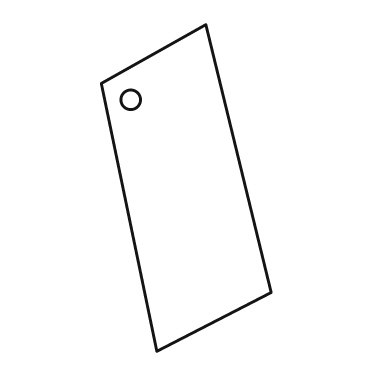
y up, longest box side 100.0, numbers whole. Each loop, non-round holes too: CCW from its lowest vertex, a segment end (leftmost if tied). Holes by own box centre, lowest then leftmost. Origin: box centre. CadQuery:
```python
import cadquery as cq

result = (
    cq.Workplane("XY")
    .moveTo(-9.0, -50.0)
    .lineTo(26.0, -32.0)
    .lineTo(6.0, 50.0)
    .lineTo(-26.0, 32.0)
    .close()
    .moveTo(-17.0, 27.0)
    .circle(3.0)
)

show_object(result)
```